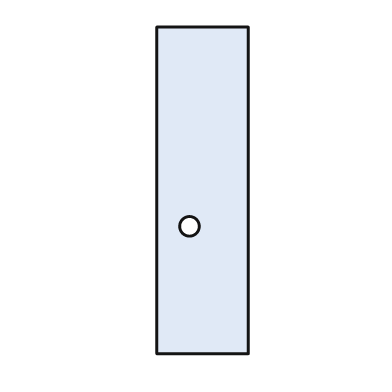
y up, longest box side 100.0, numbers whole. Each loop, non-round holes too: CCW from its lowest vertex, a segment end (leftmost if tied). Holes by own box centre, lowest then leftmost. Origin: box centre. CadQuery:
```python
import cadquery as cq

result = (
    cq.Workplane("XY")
    .moveTo(-14.0, -50.0)
    .lineTo(14.0, -50.0)
    .lineTo(14.0, 50.0)
    .lineTo(-14.0, 50.0)
    .close()
    .moveTo(-4.0, -11.0)
    .circle(3.0)
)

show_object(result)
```